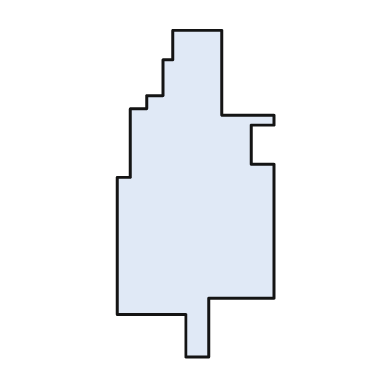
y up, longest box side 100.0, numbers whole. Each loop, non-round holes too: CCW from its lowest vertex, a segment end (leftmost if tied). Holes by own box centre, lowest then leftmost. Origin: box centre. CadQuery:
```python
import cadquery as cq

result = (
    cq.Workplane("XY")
    .moveTo(-3.0, -50.0)
    .lineTo(4.0, -50.0)
    .lineTo(4.0, -32.0)
    .lineTo(24.0, -32.0)
    .lineTo(24.0, 9.0)
    .lineTo(17.0, 9.0)
    .lineTo(17.0, 21.0)
    .lineTo(24.0, 21.0)
    .lineTo(24.0, 24.0)
    .lineTo(8.0, 24.0)
    .lineTo(8.0, 50.0)
    .lineTo(-7.0, 50.0)
    .lineTo(-7.0, 41.0)
    .lineTo(-10.0, 41.0)
    .lineTo(-10.0, 30.0)
    .lineTo(-15.0, 30.0)
    .lineTo(-15.0, 26.0)
    .lineTo(-20.0, 26.0)
    .lineTo(-20.0, 5.0)
    .lineTo(-24.0, 5.0)
    .lineTo(-24.0, -37.0)
    .lineTo(-3.0, -37.0)
    .close()
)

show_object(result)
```